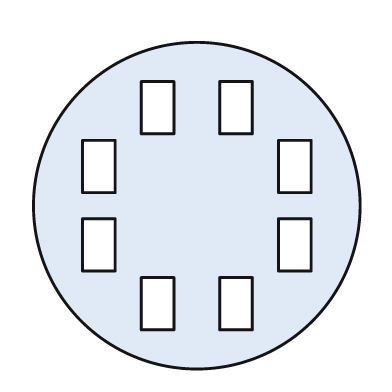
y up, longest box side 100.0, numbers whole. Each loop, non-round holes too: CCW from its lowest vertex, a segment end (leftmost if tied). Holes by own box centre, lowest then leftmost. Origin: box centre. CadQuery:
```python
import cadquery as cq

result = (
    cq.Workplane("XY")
    .moveTo(0.0, 0.0)
    .circle(50.0)
    .moveTo(-17.0, -38.0)
    .lineTo(-7.0, -38.0)
    .lineTo(-7.0, -22.0)
    .lineTo(-17.0, -22.0)
    .close()
    .moveTo(7.0, -38.0)
    .lineTo(17.0, -38.0)
    .lineTo(17.0, -22.0)
    .lineTo(7.0, -22.0)
    .close()
    .moveTo(-35.0, -20.0)
    .lineTo(-25.0, -20.0)
    .lineTo(-25.0, -4.0)
    .lineTo(-35.0, -4.0)
    .close()
    .moveTo(25.0, -20.0)
    .lineTo(35.0, -20.0)
    .lineTo(35.0, -4.0)
    .lineTo(25.0, -4.0)
    .close()
    .moveTo(-35.0, 4.0)
    .lineTo(-25.0, 4.0)
    .lineTo(-25.0, 20.0)
    .lineTo(-35.0, 20.0)
    .close()
    .moveTo(25.0, 4.0)
    .lineTo(35.0, 4.0)
    .lineTo(35.0, 20.0)
    .lineTo(25.0, 20.0)
    .close()
    .moveTo(-17.0, 22.0)
    .lineTo(-7.0, 22.0)
    .lineTo(-7.0, 38.0)
    .lineTo(-17.0, 38.0)
    .close()
    .moveTo(7.0, 22.0)
    .lineTo(17.0, 22.0)
    .lineTo(17.0, 38.0)
    .lineTo(7.0, 38.0)
    .close()
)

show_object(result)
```